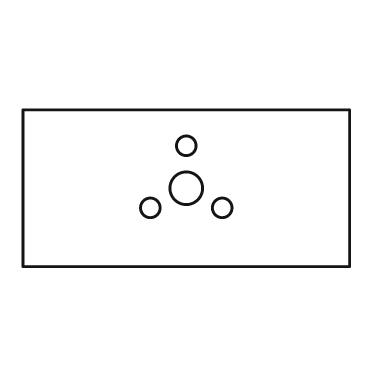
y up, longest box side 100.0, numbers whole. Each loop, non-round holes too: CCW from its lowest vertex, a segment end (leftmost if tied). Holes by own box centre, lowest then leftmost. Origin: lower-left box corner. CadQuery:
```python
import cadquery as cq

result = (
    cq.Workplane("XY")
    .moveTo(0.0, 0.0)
    .lineTo(100.0, 0.0)
    .lineTo(100.0, 48.0)
    .lineTo(0.0, 48.0)
    .close()
    .moveTo(39.0, 18.0)
    .circle(3.0)
    .moveTo(61.0, 18.0)
    .circle(3.0)
    .moveTo(50.0, 24.0)
    .circle(5.0)
    .moveTo(50.0, 37.0)
    .circle(3.0)
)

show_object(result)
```